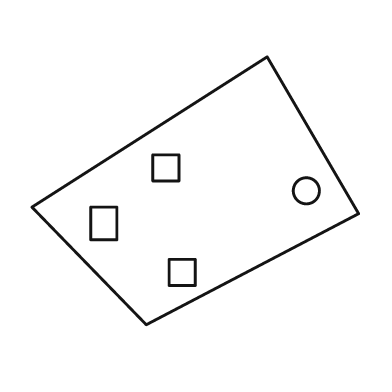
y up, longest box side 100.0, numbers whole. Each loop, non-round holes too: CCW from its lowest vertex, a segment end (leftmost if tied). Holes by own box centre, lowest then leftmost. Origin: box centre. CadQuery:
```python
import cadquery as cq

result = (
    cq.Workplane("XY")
    .moveTo(-15.0, -41.0)
    .lineTo(50.0, -7.0)
    .lineTo(22.0, 41.0)
    .lineTo(-50.0, -5.0)
    .close()
    .moveTo(-8.0, -29.0)
    .lineTo(0.0, -29.0)
    .lineTo(0.0, -21.0)
    .lineTo(-8.0, -21.0)
    .close()
    .moveTo(-32.0, -15.0)
    .lineTo(-24.0, -15.0)
    .lineTo(-24.0, -5.0)
    .lineTo(-32.0, -5.0)
    .close()
    .moveTo(34.0, 0.0)
    .circle(4.0)
    .moveTo(-13.0, 3.0)
    .lineTo(-5.0, 3.0)
    .lineTo(-5.0, 11.0)
    .lineTo(-13.0, 11.0)
    .close()
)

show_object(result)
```